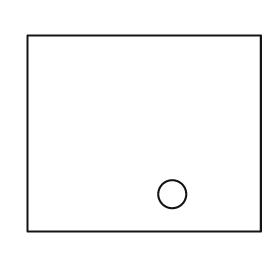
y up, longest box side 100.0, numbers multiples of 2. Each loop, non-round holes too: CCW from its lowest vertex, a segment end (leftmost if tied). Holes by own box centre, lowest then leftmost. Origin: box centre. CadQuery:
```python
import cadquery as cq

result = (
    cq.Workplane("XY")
    .moveTo(-50.0, -42.0)
    .lineTo(50.0, -42.0)
    .lineTo(50.0, 42.0)
    .lineTo(-50.0, 42.0)
    .close()
    .moveTo(12.0, -26.0)
    .circle(6.0)
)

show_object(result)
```